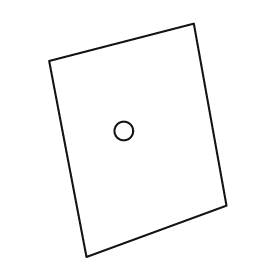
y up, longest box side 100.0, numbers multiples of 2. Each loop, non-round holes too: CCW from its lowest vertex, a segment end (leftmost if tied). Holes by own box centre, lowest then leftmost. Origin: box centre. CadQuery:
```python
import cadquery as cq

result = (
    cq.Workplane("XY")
    .moveTo(-22.0, -50.0)
    .lineTo(38.0, -28.0)
    .lineTo(24.0, 50.0)
    .lineTo(-38.0, 34.0)
    .close()
    .moveTo(-6.0, 4.0)
    .circle(4.0)
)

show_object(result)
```